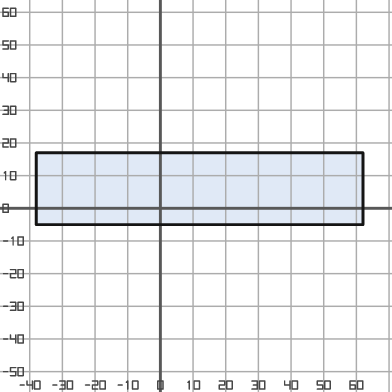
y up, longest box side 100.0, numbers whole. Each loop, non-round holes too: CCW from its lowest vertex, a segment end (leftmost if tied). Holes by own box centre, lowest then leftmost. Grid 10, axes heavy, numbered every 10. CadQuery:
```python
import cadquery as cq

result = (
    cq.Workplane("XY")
    .moveTo(-38.0, -5.0)
    .lineTo(62.0, -5.0)
    .lineTo(62.0, 17.0)
    .lineTo(-38.0, 17.0)
    .close()
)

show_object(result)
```